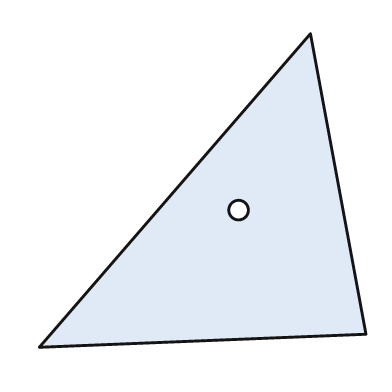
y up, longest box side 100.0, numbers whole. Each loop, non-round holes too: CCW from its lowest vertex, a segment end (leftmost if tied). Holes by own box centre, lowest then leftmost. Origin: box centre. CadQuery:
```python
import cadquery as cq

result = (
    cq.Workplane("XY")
    .moveTo(-50.0, -48.0)
    .lineTo(50.0, -44.0)
    .lineTo(33.0, 48.0)
    .close()
    .moveTo(11.0, -6.0)
    .circle(3.0)
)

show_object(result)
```